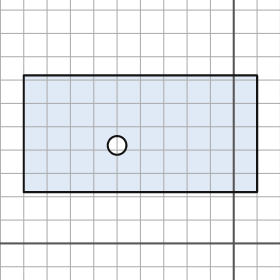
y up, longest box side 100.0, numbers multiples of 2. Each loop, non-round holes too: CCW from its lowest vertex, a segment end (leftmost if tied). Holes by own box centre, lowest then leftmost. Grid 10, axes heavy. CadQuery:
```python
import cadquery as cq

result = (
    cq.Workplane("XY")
    .moveTo(-90.0, 22.0)
    .lineTo(10.0, 22.0)
    .lineTo(10.0, 72.0)
    .lineTo(-90.0, 72.0)
    .close()
    .moveTo(-50.0, 42.0)
    .circle(4.0)
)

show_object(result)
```